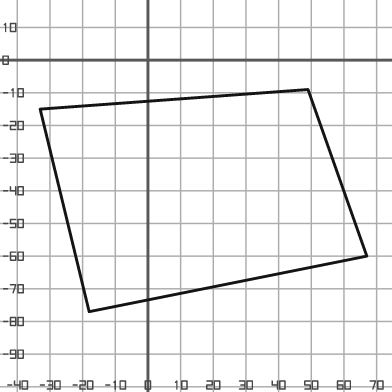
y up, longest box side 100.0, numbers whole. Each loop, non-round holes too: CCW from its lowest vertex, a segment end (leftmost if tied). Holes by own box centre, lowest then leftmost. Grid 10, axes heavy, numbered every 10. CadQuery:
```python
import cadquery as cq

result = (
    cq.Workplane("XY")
    .moveTo(-18.0, -77.0)
    .lineTo(67.0, -60.0)
    .lineTo(49.0, -9.0)
    .lineTo(-33.0, -15.0)
    .close()
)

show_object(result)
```